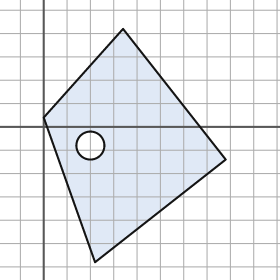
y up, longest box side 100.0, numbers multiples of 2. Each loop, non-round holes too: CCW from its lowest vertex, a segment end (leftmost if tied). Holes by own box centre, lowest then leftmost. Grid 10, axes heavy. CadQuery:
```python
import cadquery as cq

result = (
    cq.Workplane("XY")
    .moveTo(22.0, -58.0)
    .lineTo(78.0, -14.0)
    .lineTo(34.0, 42.0)
    .lineTo(0.0, 4.0)
    .close()
    .moveTo(20.0, -8.0)
    .circle(6.0)
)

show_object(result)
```